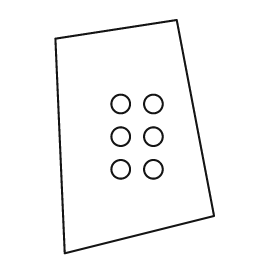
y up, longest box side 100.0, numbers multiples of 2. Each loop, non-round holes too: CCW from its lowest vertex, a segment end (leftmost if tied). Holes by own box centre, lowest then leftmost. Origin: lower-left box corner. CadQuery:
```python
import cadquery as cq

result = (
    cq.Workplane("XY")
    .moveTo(4.0, 0.0)
    .lineTo(68.0, 16.0)
    .lineTo(52.0, 100.0)
    .lineTo(0.0, 92.0)
    .close()
    .moveTo(28.0, 36.0)
    .circle(4.0)
    .moveTo(42.0, 36.0)
    .circle(4.0)
    .moveTo(28.0, 50.0)
    .circle(4.0)
    .moveTo(42.0, 50.0)
    .circle(4.0)
    .moveTo(28.0, 64.0)
    .circle(4.0)
    .moveTo(42.0, 64.0)
    .circle(4.0)
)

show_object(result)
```